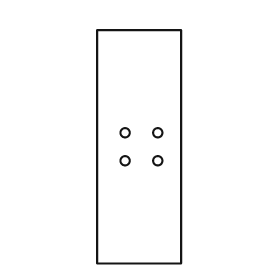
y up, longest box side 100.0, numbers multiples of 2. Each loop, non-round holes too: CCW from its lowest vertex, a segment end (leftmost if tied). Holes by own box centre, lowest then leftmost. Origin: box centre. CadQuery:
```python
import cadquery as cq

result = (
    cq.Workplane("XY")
    .moveTo(-18.0, -50.0)
    .lineTo(18.0, -50.0)
    .lineTo(18.0, 50.0)
    .lineTo(-18.0, 50.0)
    .close()
    .moveTo(-6.0, -6.0)
    .circle(2.0)
    .moveTo(8.0, -6.0)
    .circle(2.0)
    .moveTo(-6.0, 6.0)
    .circle(2.0)
    .moveTo(8.0, 6.0)
    .circle(2.0)
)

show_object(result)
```